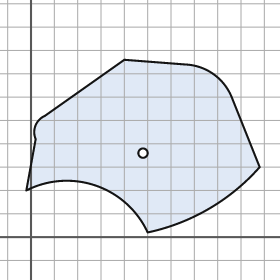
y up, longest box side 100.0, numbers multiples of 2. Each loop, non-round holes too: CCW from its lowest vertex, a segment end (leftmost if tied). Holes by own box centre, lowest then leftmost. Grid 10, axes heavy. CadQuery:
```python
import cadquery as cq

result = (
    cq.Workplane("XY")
    .moveTo(50.0, 2.0)
    .threePointArc((76.0, 12.0), (98.0, 30.0))
    .lineTo(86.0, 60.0)
    .threePointArc((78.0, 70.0), (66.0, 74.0))
    .lineTo(40.0, 76.0)
    .lineTo(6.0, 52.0)
    .threePointArc((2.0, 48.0), (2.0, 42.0))
    .lineTo(-2.0, 20.0)
    .threePointArc((28.0, 22.0), (50.0, 2.0))
    .close()
    .moveTo(48.0, 36.0)
    .circle(2.0)
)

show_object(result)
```